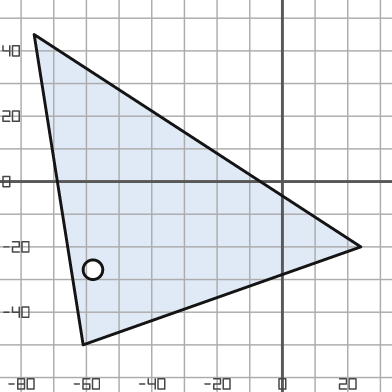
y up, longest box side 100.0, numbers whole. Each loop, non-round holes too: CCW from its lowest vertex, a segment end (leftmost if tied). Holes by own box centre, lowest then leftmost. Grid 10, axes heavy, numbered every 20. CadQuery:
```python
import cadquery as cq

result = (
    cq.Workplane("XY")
    .moveTo(-61.0, -50.0)
    .lineTo(24.0, -20.0)
    .lineTo(-76.0, 45.0)
    .close()
    .moveTo(-58.0, -27.0)
    .circle(3.0)
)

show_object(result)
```